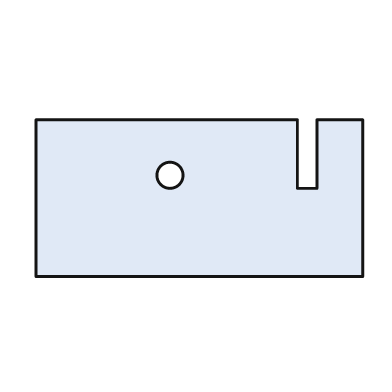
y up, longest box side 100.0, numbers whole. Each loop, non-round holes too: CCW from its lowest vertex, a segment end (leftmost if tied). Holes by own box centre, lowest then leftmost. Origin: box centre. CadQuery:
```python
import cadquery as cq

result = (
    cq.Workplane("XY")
    .moveTo(-50.0, -24.0)
    .lineTo(50.0, -24.0)
    .lineTo(50.0, 24.0)
    .lineTo(36.0, 24.0)
    .lineTo(36.0, 3.0)
    .lineTo(30.0, 3.0)
    .lineTo(30.0, 24.0)
    .lineTo(-50.0, 24.0)
    .close()
    .moveTo(-9.0, 7.0)
    .circle(4.0)
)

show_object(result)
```